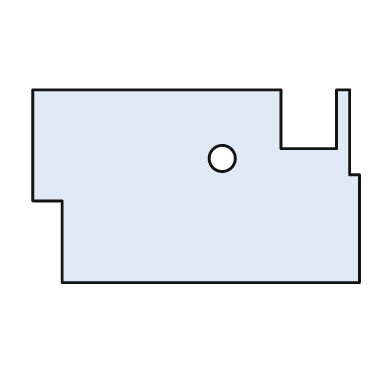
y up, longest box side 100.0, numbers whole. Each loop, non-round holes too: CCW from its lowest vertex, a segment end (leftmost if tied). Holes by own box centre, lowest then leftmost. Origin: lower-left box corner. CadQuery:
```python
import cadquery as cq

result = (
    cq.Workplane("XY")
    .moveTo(9.0, 0.0)
    .lineTo(100.0, 0.0)
    .lineTo(100.0, 33.0)
    .lineTo(97.0, 33.0)
    .lineTo(97.0, 59.0)
    .lineTo(93.0, 59.0)
    .lineTo(93.0, 41.0)
    .lineTo(76.0, 41.0)
    .lineTo(76.0, 59.0)
    .lineTo(0.0, 59.0)
    .lineTo(0.0, 25.0)
    .lineTo(9.0, 25.0)
    .close()
    .moveTo(58.0, 38.0)
    .circle(4.0)
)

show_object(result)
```